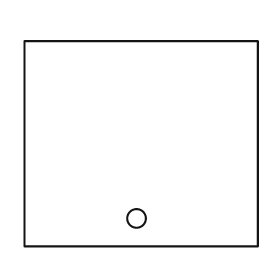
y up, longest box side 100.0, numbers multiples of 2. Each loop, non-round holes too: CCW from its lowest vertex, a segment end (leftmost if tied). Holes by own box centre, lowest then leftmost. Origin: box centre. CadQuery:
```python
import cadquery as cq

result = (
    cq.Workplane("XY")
    .moveTo(-50.0, -44.0)
    .lineTo(50.0, -44.0)
    .lineTo(50.0, 44.0)
    .lineTo(-50.0, 44.0)
    .close()
    .moveTo(-2.0, -32.0)
    .circle(4.0)
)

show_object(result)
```